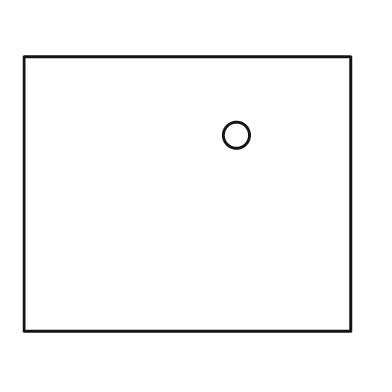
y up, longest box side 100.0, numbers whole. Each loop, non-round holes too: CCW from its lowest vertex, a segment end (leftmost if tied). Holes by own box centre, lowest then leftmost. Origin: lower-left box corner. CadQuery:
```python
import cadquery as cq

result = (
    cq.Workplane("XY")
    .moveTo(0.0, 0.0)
    .lineTo(100.0, 0.0)
    .lineTo(100.0, 84.0)
    .lineTo(0.0, 84.0)
    .close()
    .moveTo(65.0, 60.0)
    .circle(4.0)
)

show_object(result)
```